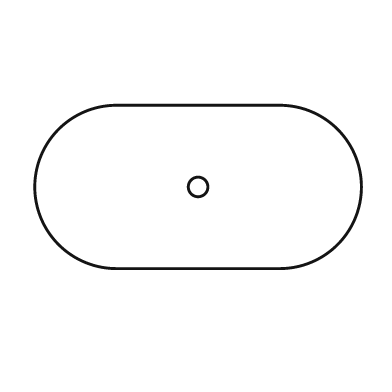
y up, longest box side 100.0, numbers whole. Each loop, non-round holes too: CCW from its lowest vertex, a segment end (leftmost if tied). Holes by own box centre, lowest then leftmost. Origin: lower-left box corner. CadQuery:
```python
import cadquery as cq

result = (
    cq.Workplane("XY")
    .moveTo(25.0, 0.0)
    .lineTo(75.0, 0.0)
    .threePointArc((100.0, 25.0), (75.0, 50.0))
    .lineTo(25.0, 50.0)
    .threePointArc((0.0, 25.0), (25.0, 0.0))
    .close()
    .moveTo(50.0, 25.0)
    .circle(3.0)
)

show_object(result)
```